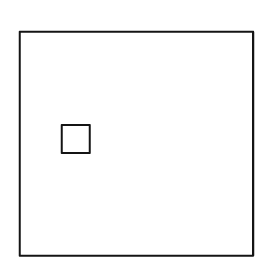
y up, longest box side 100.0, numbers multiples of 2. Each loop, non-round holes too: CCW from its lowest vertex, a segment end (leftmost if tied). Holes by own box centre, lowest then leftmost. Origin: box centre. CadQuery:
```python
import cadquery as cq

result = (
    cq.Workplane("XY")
    .moveTo(-50.0, -48.0)
    .lineTo(50.0, -48.0)
    .lineTo(50.0, 48.0)
    .lineTo(-50.0, 48.0)
    .close()
    .moveTo(-32.0, -4.0)
    .lineTo(-20.0, -4.0)
    .lineTo(-20.0, 8.0)
    .lineTo(-32.0, 8.0)
    .close()
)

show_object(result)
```